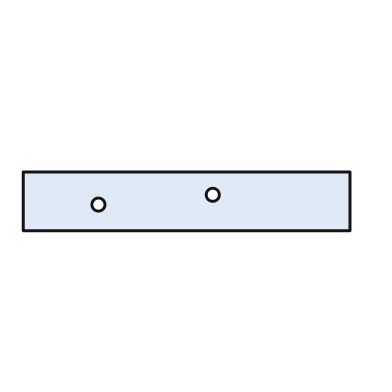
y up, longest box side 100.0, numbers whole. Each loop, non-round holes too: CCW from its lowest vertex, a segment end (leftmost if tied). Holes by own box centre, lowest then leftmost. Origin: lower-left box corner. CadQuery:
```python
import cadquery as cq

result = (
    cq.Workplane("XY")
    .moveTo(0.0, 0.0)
    .lineTo(100.0, 0.0)
    .lineTo(100.0, 18.0)
    .lineTo(0.0, 18.0)
    .close()
    .moveTo(23.0, 8.0)
    .circle(2.0)
    .moveTo(58.0, 11.0)
    .circle(2.0)
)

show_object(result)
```